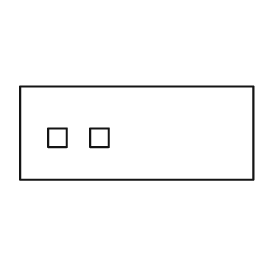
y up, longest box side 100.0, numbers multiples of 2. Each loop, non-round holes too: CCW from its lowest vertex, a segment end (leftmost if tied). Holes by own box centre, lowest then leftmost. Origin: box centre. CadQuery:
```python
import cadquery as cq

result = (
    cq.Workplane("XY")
    .moveTo(-50.0, -20.0)
    .lineTo(50.0, -20.0)
    .lineTo(50.0, 20.0)
    .lineTo(-50.0, 20.0)
    .close()
    .moveTo(-38.0, -6.0)
    .lineTo(-30.0, -6.0)
    .lineTo(-30.0, 2.0)
    .lineTo(-38.0, 2.0)
    .close()
    .moveTo(-20.0, -6.0)
    .lineTo(-12.0, -6.0)
    .lineTo(-12.0, 2.0)
    .lineTo(-20.0, 2.0)
    .close()
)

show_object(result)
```